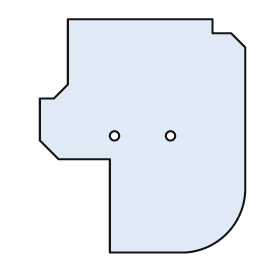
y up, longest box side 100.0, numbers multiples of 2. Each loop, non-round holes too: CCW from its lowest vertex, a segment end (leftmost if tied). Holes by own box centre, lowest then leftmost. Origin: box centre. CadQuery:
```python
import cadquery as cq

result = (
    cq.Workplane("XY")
    .moveTo(-14.0, -50.0)
    .lineTo(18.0, -50.0)
    .threePointArc((36.0, -42.0), (44.0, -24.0))
    .lineTo(44.0, 38.0)
    .lineTo(38.0, 44.0)
    .lineTo(30.0, 44.0)
    .lineTo(30.0, 50.0)
    .lineTo(-32.0, 50.0)
    .lineTo(-32.0, 22.0)
    .lineTo(-38.0, 16.0)
    .lineTo(-44.0, 16.0)
    .lineTo(-44.0, -2.0)
    .lineTo(-36.0, -10.0)
    .lineTo(-14.0, -10.0)
    .close()
    .moveTo(-12.0, 0.0)
    .circle(2.0)
    .moveTo(12.0, 0.0)
    .circle(2.0)
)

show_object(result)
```